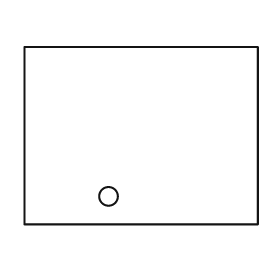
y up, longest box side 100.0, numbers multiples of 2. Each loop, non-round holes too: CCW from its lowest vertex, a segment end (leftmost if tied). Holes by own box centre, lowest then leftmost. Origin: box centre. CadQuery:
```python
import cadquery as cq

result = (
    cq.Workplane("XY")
    .moveTo(-50.0, -38.0)
    .lineTo(50.0, -38.0)
    .lineTo(50.0, 38.0)
    .lineTo(-50.0, 38.0)
    .close()
    .moveTo(-14.0, -26.0)
    .circle(4.0)
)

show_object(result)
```